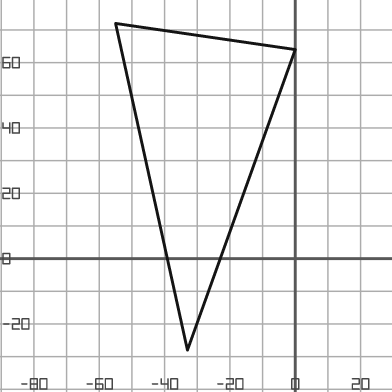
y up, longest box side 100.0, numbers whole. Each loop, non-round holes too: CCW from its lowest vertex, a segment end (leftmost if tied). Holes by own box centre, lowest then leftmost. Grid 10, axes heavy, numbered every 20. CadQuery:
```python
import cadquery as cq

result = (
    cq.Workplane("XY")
    .moveTo(-33.0, -28.0)
    .lineTo(0.0, 64.0)
    .lineTo(-55.0, 72.0)
    .close()
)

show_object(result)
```